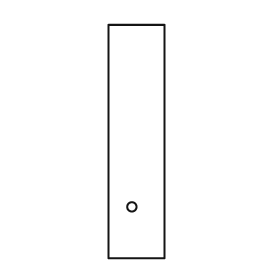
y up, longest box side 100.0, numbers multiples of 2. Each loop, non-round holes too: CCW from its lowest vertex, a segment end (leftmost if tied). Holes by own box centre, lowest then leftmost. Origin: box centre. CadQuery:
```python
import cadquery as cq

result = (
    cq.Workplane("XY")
    .moveTo(-12.0, -50.0)
    .lineTo(12.0, -50.0)
    .lineTo(12.0, 50.0)
    .lineTo(-12.0, 50.0)
    .close()
    .moveTo(-2.0, -28.0)
    .circle(2.0)
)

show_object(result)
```